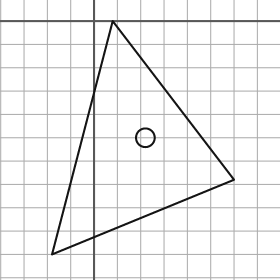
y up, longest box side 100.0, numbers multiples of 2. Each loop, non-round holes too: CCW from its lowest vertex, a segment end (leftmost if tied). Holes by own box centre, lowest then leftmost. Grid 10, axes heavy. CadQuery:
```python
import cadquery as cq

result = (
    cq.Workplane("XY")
    .moveTo(-18.0, -100.0)
    .lineTo(60.0, -68.0)
    .lineTo(8.0, 0.0)
    .close()
    .moveTo(22.0, -50.0)
    .circle(4.0)
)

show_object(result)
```